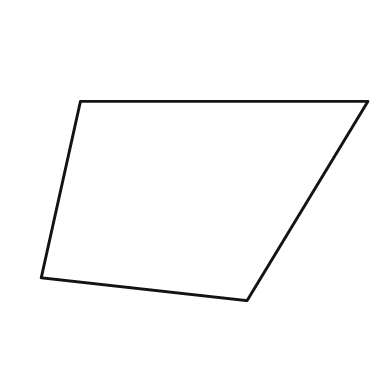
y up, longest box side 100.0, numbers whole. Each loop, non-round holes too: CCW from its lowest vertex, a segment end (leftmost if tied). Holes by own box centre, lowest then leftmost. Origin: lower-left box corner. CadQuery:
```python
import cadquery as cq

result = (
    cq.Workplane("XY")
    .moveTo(63.0, 0.0)
    .lineTo(100.0, 61.0)
    .lineTo(12.0, 61.0)
    .lineTo(0.0, 7.0)
    .close()
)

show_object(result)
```